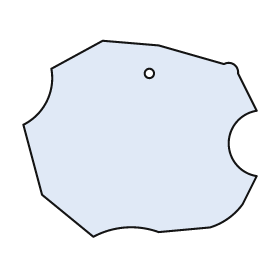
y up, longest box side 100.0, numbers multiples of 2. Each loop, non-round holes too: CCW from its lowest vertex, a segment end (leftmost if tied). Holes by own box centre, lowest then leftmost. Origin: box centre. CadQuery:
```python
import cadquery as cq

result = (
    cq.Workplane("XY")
    .moveTo(-20.0, -42.0)
    .threePointArc((-6.0, -38.0), (8.0, -40.0))
    .lineTo(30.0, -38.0)
    .threePointArc((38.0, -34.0), (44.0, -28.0))
    .lineTo(50.0, -16.0)
    .threePointArc((38.0, -2.0), (50.0, 12.0))
    .lineTo(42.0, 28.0)
    .threePointArc((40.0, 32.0), (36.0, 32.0))
    .lineTo(8.0, 40.0)
    .lineTo(-16.0, 42.0)
    .lineTo(-38.0, 30.0)
    .threePointArc((-40.0, 16.0), (-50.0, 6.0))
    .lineTo(-42.0, -24.0)
    .close()
    .moveTo(4.0, 28.0)
    .circle(2.0)
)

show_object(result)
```